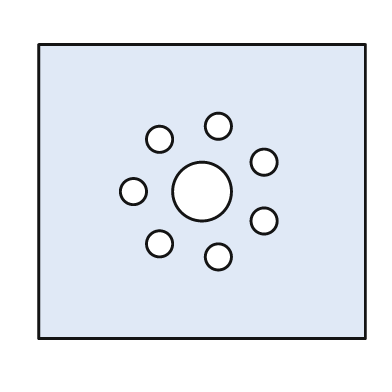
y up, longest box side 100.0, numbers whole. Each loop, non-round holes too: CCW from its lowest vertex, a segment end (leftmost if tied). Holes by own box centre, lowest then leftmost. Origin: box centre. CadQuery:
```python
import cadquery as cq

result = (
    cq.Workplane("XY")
    .moveTo(-50.0, -45.0)
    .lineTo(50.0, -45.0)
    .lineTo(50.0, 45.0)
    .lineTo(-50.0, 45.0)
    .close()
    .moveTo(5.0, -20.0)
    .circle(4.0)
    .moveTo(-13.0, -16.0)
    .circle(4.0)
    .moveTo(19.0, -9.0)
    .circle(4.0)
    .moveTo(-21.0, 0.0)
    .circle(4.0)
    .moveTo(0.0, 0.0)
    .circle(9.0)
    .moveTo(19.0, 9.0)
    .circle(4.0)
    .moveTo(-13.0, 16.0)
    .circle(4.0)
    .moveTo(5.0, 20.0)
    .circle(4.0)
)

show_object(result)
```